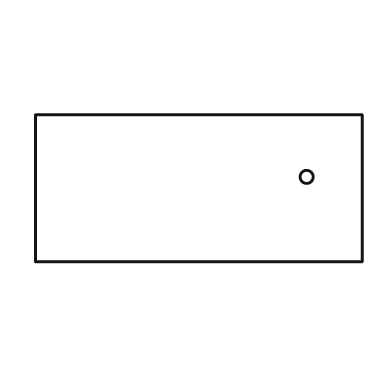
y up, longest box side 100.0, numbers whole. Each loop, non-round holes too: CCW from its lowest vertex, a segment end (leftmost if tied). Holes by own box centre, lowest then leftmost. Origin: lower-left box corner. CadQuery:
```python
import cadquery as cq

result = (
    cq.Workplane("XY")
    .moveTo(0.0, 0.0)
    .lineTo(100.0, 0.0)
    .lineTo(100.0, 45.0)
    .lineTo(0.0, 45.0)
    .close()
    .moveTo(83.0, 26.0)
    .circle(2.0)
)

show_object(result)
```